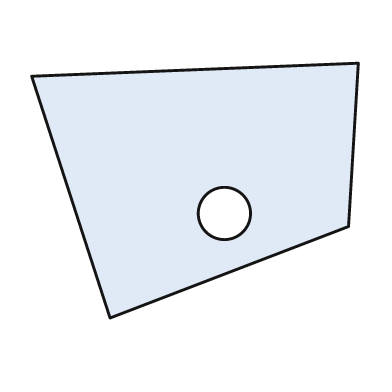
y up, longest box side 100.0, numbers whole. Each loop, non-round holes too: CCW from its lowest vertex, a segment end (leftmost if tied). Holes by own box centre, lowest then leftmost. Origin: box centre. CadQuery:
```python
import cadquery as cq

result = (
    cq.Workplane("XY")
    .moveTo(-26.0, -39.0)
    .lineTo(47.0, -11.0)
    .lineTo(50.0, 39.0)
    .lineTo(-50.0, 35.0)
    .close()
    .moveTo(9.0, -7.0)
    .circle(8.0)
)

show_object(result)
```